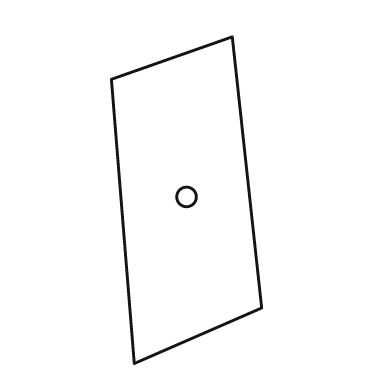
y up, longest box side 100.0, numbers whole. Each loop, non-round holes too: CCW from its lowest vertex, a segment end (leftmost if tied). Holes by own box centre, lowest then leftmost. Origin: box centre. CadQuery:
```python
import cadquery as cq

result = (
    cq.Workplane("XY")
    .moveTo(-16.0, -50.0)
    .lineTo(23.0, -33.0)
    .lineTo(14.0, 50.0)
    .lineTo(-23.0, 37.0)
    .close()
    .moveTo(0.0, 1.0)
    .circle(3.0)
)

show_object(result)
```